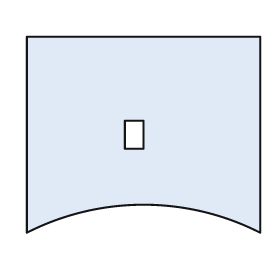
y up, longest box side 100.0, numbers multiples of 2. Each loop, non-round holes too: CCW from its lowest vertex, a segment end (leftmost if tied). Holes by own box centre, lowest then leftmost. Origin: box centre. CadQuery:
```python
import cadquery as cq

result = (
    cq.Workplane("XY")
    .moveTo(-50.0, -42.0)
    .threePointArc((0.0, -30.0), (50.0, -42.0))
    .lineTo(50.0, 42.0)
    .lineTo(-50.0, 42.0)
    .close()
    .moveTo(-8.0, -6.0)
    .lineTo(0.0, -6.0)
    .lineTo(0.0, 6.0)
    .lineTo(-8.0, 6.0)
    .close()
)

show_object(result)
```